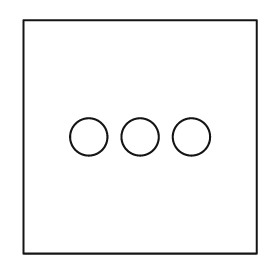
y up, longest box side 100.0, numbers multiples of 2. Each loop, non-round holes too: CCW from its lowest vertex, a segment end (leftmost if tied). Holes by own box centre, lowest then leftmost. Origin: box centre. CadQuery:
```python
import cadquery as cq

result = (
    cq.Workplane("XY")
    .moveTo(-50.0, -50.0)
    .lineTo(50.0, -50.0)
    .lineTo(50.0, 50.0)
    .lineTo(-50.0, 50.0)
    .close()
    .moveTo(-22.0, 0.0)
    .circle(8.0)
    .moveTo(0.0, 0.0)
    .circle(8.0)
    .moveTo(22.0, 0.0)
    .circle(8.0)
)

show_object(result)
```